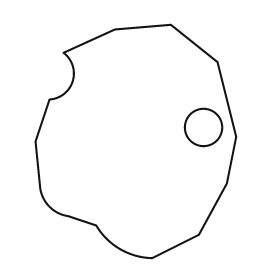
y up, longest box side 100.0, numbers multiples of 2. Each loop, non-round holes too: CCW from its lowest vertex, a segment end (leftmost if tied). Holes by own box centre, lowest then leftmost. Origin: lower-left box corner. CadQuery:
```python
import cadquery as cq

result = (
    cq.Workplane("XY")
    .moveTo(50.0, 0.0)
    .lineTo(70.0, 10.0)
    .lineTo(82.0, 32.0)
    .lineTo(86.0, 52.0)
    .lineTo(78.0, 84.0)
    .lineTo(58.0, 100.0)
    .lineTo(34.0, 98.0)
    .lineTo(12.0, 88.0)
    .threePointArc((16.0, 76.0), (6.0, 68.0))
    .lineTo(0.0, 50.0)
    .lineTo(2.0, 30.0)
    .threePointArc((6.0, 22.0), (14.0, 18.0))
    .lineTo(26.0, 14.0)
    .threePointArc((36.0, 4.0), (50.0, 0.0))
    .close()
    .moveTo(72.0, 56.0)
    .circle(8.0)
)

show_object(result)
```